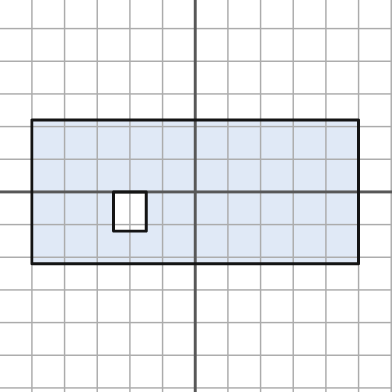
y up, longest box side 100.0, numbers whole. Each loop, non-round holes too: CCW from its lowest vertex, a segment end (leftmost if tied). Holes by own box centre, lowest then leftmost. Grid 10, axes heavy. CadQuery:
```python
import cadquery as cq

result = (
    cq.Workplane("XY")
    .moveTo(-50.0, -22.0)
    .lineTo(50.0, -22.0)
    .lineTo(50.0, 22.0)
    .lineTo(-50.0, 22.0)
    .close()
    .moveTo(-25.0, -12.0)
    .lineTo(-15.0, -12.0)
    .lineTo(-15.0, 0.0)
    .lineTo(-25.0, 0.0)
    .close()
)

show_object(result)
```